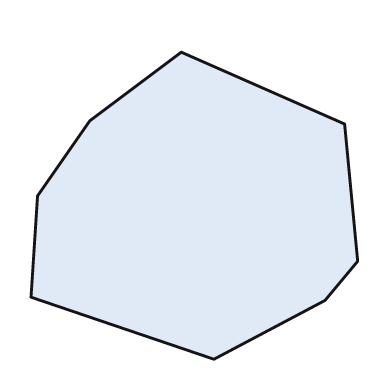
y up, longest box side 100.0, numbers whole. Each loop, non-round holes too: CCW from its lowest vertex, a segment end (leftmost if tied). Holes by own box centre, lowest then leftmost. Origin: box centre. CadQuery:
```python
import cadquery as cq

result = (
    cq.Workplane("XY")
    .moveTo(6.0, -47.0)
    .lineTo(40.0, -29.0)
    .lineTo(50.0, -17.0)
    .lineTo(46.0, 25.0)
    .lineTo(-4.0, 47.0)
    .lineTo(-32.0, 26.0)
    .lineTo(-48.0, 3.0)
    .lineTo(-50.0, -28.0)
    .close()
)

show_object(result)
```